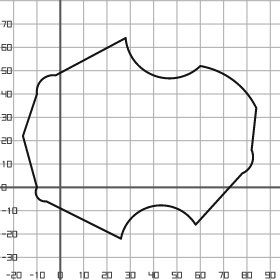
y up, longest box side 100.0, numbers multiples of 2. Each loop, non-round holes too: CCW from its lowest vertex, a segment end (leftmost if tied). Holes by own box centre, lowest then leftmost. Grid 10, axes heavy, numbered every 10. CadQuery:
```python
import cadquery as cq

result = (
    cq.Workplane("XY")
    .moveTo(26.0, -22.0)
    .threePointArc((40.0, -8.0), (58.0, -16.0))
    .lineTo(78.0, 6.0)
    .threePointArc((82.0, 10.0), (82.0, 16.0))
    .lineTo(84.0, 34.0)
    .threePointArc((74.0, 46.0), (60.0, 52.0))
    .threePointArc((40.0, 48.0), (28.0, 64.0))
    .lineTo(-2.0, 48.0)
    .threePointArc((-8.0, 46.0), (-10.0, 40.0))
    .lineTo(-16.0, 22.0)
    .lineTo(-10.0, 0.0)
    .threePointArc((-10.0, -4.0), (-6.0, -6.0))
    .close()
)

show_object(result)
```